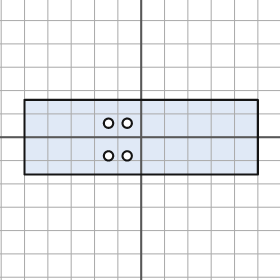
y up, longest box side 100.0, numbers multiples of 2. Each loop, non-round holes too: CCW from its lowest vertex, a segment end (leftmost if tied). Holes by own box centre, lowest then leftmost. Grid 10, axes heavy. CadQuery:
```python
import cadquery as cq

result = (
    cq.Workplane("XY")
    .moveTo(-50.0, -16.0)
    .lineTo(50.0, -16.0)
    .lineTo(50.0, 16.0)
    .lineTo(-50.0, 16.0)
    .close()
    .moveTo(-14.0, -8.0)
    .circle(2.0)
    .moveTo(-6.0, -8.0)
    .circle(2.0)
    .moveTo(-14.0, 6.0)
    .circle(2.0)
    .moveTo(-6.0, 6.0)
    .circle(2.0)
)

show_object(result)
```